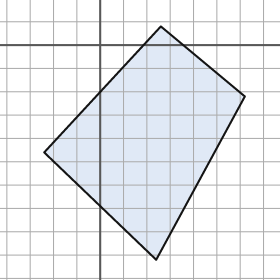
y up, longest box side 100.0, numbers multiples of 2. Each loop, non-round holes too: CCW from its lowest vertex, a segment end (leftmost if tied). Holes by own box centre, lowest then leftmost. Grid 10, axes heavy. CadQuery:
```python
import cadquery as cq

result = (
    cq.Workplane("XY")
    .moveTo(24.0, -92.0)
    .lineTo(62.0, -22.0)
    .lineTo(26.0, 8.0)
    .lineTo(-24.0, -46.0)
    .close()
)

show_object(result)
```